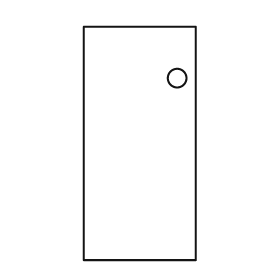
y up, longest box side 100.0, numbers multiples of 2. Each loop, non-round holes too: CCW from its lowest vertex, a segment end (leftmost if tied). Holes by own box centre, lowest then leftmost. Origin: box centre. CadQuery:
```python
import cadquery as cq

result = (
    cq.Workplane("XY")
    .moveTo(-24.0, -50.0)
    .lineTo(24.0, -50.0)
    .lineTo(24.0, 50.0)
    .lineTo(-24.0, 50.0)
    .close()
    .moveTo(16.0, 28.0)
    .circle(4.0)
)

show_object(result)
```